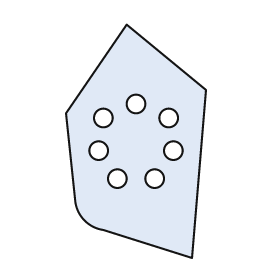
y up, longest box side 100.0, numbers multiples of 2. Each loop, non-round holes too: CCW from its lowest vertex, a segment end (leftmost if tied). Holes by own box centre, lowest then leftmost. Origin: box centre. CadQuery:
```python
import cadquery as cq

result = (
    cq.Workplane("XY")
    .moveTo(24.0, -50.0)
    .lineTo(30.0, 22.0)
    .lineTo(-4.0, 50.0)
    .lineTo(-30.0, 12.0)
    .lineTo(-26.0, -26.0)
    .threePointArc((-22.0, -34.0), (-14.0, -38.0))
    .close()
    .moveTo(-8.0, -16.0)
    .circle(4.0)
    .moveTo(8.0, -16.0)
    .circle(4.0)
    .moveTo(-16.0, -4.0)
    .circle(4.0)
    .moveTo(16.0, -4.0)
    .circle(4.0)
    .moveTo(-14.0, 10.0)
    .circle(4.0)
    .moveTo(14.0, 10.0)
    .circle(4.0)
    .moveTo(0.0, 16.0)
    .circle(4.0)
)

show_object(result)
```